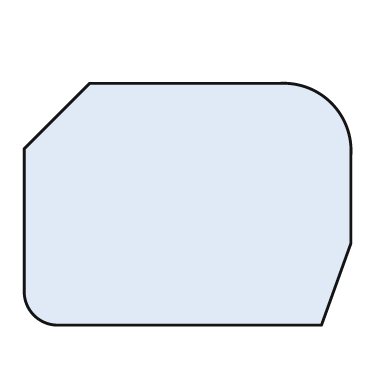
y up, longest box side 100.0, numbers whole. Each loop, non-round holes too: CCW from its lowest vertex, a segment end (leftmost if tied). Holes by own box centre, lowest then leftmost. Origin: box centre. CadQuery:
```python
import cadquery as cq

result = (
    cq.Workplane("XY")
    .moveTo(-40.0, -37.0)
    .lineTo(41.0, -37.0)
    .lineTo(50.0, -12.0)
    .lineTo(50.0, 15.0)
    .threePointArc((44.0, 31.0), (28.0, 37.0))
    .lineTo(-30.0, 37.0)
    .lineTo(-50.0, 17.0)
    .lineTo(-50.0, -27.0)
    .threePointArc((-47.0, -34.0), (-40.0, -37.0))
    .close()
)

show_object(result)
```